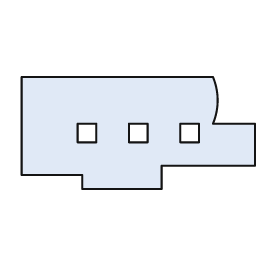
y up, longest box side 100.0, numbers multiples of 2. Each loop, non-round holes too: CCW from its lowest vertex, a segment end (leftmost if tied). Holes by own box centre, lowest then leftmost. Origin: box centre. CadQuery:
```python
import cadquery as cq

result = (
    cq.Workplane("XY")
    .moveTo(-24.0, -24.0)
    .lineTo(10.0, -24.0)
    .lineTo(10.0, -14.0)
    .lineTo(50.0, -14.0)
    .lineTo(50.0, 4.0)
    .lineTo(32.0, 4.0)
    .threePointArc((34.0, 14.0), (32.0, 24.0))
    .lineTo(-50.0, 24.0)
    .lineTo(-50.0, -18.0)
    .lineTo(-24.0, -18.0)
    .close()
    .moveTo(-26.0, -4.0)
    .lineTo(-18.0, -4.0)
    .lineTo(-18.0, 4.0)
    .lineTo(-26.0, 4.0)
    .close()
    .moveTo(-4.0, -4.0)
    .lineTo(4.0, -4.0)
    .lineTo(4.0, 4.0)
    .lineTo(-4.0, 4.0)
    .close()
    .moveTo(18.0, -4.0)
    .lineTo(26.0, -4.0)
    .lineTo(26.0, 4.0)
    .lineTo(18.0, 4.0)
    .close()
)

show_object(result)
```